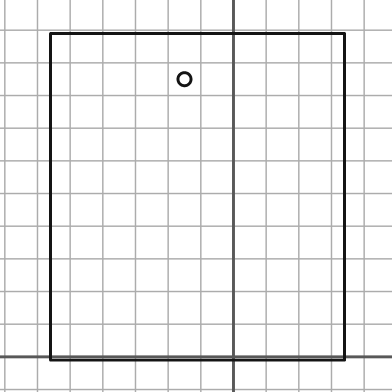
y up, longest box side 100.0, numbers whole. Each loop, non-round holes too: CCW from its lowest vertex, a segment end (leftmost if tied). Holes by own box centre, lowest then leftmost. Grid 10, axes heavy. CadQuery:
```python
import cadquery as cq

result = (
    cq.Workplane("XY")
    .moveTo(-56.0, -1.0)
    .lineTo(34.0, -1.0)
    .lineTo(34.0, 99.0)
    .lineTo(-56.0, 99.0)
    .close()
    .moveTo(-15.0, 85.0)
    .circle(2.0)
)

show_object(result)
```